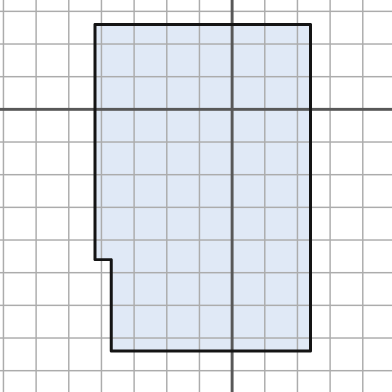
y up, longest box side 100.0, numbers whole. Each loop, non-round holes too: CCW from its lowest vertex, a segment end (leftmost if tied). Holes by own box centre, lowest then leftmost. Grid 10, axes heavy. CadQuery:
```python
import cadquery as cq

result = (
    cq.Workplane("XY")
    .moveTo(-37.0, -74.0)
    .lineTo(24.0, -74.0)
    .lineTo(24.0, 26.0)
    .lineTo(-42.0, 26.0)
    .lineTo(-42.0, -46.0)
    .lineTo(-37.0, -46.0)
    .close()
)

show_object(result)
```